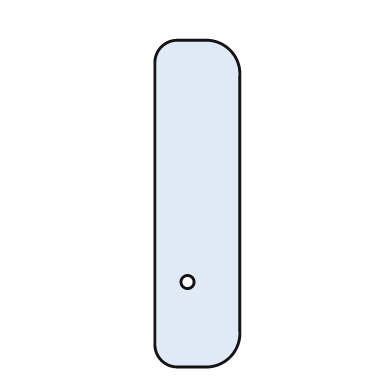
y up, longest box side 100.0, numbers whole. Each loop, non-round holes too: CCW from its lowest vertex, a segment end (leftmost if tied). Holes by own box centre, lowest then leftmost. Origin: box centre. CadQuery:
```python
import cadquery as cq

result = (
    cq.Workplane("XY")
    .moveTo(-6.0, -50.0)
    .lineTo(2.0, -50.0)
    .threePointArc((10.0, -47.0), (13.0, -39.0))
    .lineTo(13.0, 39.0)
    .threePointArc((10.0, 47.0), (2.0, 50.0))
    .lineTo(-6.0, 50.0)
    .threePointArc((-11.0, 48.0), (-13.0, 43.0))
    .lineTo(-13.0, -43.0)
    .threePointArc((-11.0, -48.0), (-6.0, -50.0))
    .close()
    .moveTo(-3.0, -24.0)
    .circle(2.0)
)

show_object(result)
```